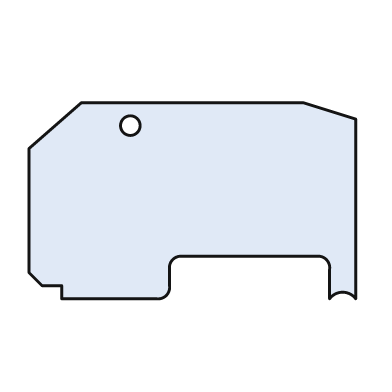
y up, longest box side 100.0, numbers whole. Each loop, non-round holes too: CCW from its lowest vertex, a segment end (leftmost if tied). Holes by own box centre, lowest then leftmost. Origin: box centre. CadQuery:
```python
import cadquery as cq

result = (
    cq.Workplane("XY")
    .moveTo(-40.0, -30.0)
    .lineTo(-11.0, -30.0)
    .threePointArc((-8.0, -29.0), (-7.0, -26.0))
    .lineTo(-7.0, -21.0)
    .threePointArc((-6.0, -18.0), (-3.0, -17.0))
    .lineTo(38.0, -17.0)
    .threePointArc((41.0, -18.0), (42.0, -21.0))
    .lineTo(42.0, -30.0)
    .threePointArc((46.0, -28.0), (50.0, -30.0))
    .lineTo(50.0, 25.0)
    .lineTo(34.0, 30.0)
    .lineTo(-34.0, 30.0)
    .lineTo(-50.0, 16.0)
    .lineTo(-50.0, -22.0)
    .lineTo(-46.0, -26.0)
    .lineTo(-40.0, -26.0)
    .close()
    .moveTo(-19.0, 23.0)
    .circle(3.0)
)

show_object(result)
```